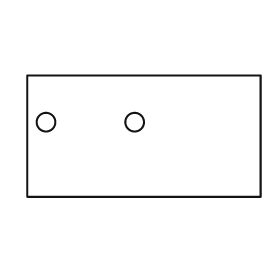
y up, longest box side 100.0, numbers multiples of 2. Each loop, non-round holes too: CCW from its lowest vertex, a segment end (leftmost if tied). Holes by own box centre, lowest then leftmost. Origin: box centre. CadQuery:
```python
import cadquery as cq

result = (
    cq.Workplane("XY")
    .moveTo(-50.0, -26.0)
    .lineTo(50.0, -26.0)
    .lineTo(50.0, 26.0)
    .lineTo(-50.0, 26.0)
    .close()
    .moveTo(-42.0, 6.0)
    .circle(4.0)
    .moveTo(-4.0, 6.0)
    .circle(4.0)
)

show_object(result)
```